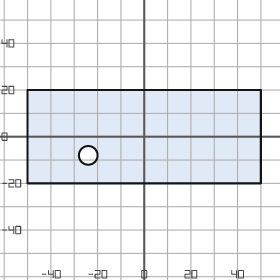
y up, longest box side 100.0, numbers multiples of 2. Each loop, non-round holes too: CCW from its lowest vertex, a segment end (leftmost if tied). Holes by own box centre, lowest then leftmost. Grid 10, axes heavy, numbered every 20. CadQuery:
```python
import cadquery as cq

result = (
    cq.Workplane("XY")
    .moveTo(-50.0, -20.0)
    .lineTo(50.0, -20.0)
    .lineTo(50.0, 20.0)
    .lineTo(-50.0, 20.0)
    .close()
    .moveTo(-24.0, -8.0)
    .circle(4.0)
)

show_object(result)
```